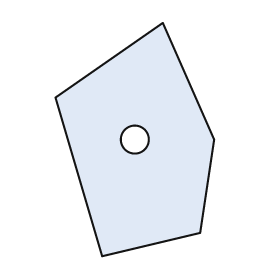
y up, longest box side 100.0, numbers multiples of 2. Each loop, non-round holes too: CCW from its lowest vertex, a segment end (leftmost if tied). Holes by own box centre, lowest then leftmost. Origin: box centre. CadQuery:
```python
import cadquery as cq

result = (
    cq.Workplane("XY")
    .moveTo(-14.0, -50.0)
    .lineTo(28.0, -40.0)
    .lineTo(34.0, 0.0)
    .lineTo(12.0, 50.0)
    .lineTo(-34.0, 18.0)
    .close()
    .moveTo(0.0, 0.0)
    .circle(6.0)
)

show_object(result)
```